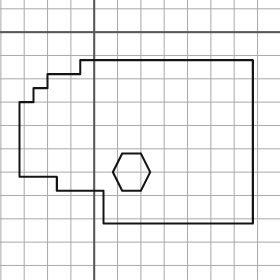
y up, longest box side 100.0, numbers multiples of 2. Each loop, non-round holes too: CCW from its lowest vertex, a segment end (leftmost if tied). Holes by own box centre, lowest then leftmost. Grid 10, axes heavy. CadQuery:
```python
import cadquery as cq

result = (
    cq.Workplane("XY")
    .moveTo(4.0, -82.0)
    .lineTo(68.0, -82.0)
    .lineTo(68.0, -12.0)
    .lineTo(-6.0, -12.0)
    .lineTo(-6.0, -18.0)
    .lineTo(-20.0, -18.0)
    .lineTo(-20.0, -24.0)
    .lineTo(-26.0, -24.0)
    .lineTo(-26.0, -30.0)
    .lineTo(-32.0, -30.0)
    .lineTo(-32.0, -62.0)
    .lineTo(-16.0, -62.0)
    .lineTo(-16.0, -68.0)
    .lineTo(4.0, -68.0)
    .close()
    .moveTo(12.0, -68.0)
    .lineTo(20.0, -68.0)
    .lineTo(24.0, -60.0)
    .lineTo(20.0, -52.0)
    .lineTo(12.0, -52.0)
    .lineTo(8.0, -60.0)
    .close()
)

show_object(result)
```